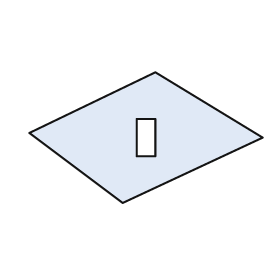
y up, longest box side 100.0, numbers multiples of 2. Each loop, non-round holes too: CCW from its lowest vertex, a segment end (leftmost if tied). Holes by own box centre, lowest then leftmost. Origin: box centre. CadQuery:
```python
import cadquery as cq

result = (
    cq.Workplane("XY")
    .moveTo(-10.0, -28.0)
    .lineTo(50.0, 0.0)
    .lineTo(4.0, 28.0)
    .lineTo(-50.0, 2.0)
    .close()
    .moveTo(-4.0, -8.0)
    .lineTo(4.0, -8.0)
    .lineTo(4.0, 8.0)
    .lineTo(-4.0, 8.0)
    .close()
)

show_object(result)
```